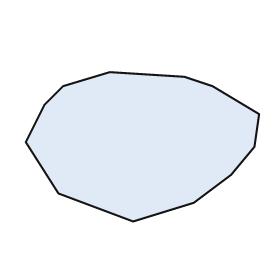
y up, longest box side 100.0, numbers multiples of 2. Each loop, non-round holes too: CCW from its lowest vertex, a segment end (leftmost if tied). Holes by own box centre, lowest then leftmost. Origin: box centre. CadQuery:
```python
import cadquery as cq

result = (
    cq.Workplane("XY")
    .moveTo(-4.0, -32.0)
    .lineTo(22.0, -24.0)
    .lineTo(38.0, -12.0)
    .lineTo(48.0, 0.0)
    .lineTo(50.0, 14.0)
    .lineTo(30.0, 26.0)
    .lineTo(18.0, 30.0)
    .lineTo(-14.0, 32.0)
    .lineTo(-34.0, 26.0)
    .lineTo(-42.0, 18.0)
    .lineTo(-50.0, 2.0)
    .lineTo(-36.0, -20.0)
    .close()
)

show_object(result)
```